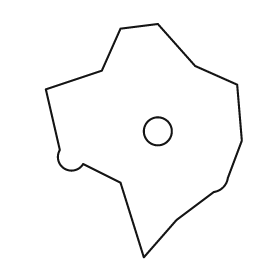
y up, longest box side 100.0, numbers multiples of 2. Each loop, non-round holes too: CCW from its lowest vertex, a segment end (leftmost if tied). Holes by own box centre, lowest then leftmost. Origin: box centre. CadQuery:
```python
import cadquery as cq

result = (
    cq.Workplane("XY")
    .moveTo(0.0, -50.0)
    .lineTo(14.0, -34.0)
    .lineTo(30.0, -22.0)
    .threePointArc((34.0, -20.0), (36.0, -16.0))
    .lineTo(42.0, 0.0)
    .lineTo(40.0, 24.0)
    .lineTo(22.0, 32.0)
    .lineTo(6.0, 50.0)
    .lineTo(-10.0, 48.0)
    .lineTo(-18.0, 30.0)
    .lineTo(-42.0, 22.0)
    .lineTo(-36.0, -4.0)
    .threePointArc((-34.0, -12.0), (-26.0, -10.0))
    .lineTo(-10.0, -18.0)
    .close()
    .moveTo(6.0, 4.0)
    .circle(6.0)
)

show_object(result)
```